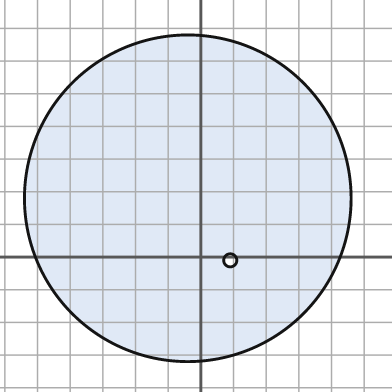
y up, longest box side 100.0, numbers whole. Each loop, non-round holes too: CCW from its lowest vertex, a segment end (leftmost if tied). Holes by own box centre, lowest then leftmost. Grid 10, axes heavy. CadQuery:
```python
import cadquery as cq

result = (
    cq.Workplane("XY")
    .moveTo(-4.0, 18.0)
    .circle(50.0)
    .moveTo(9.0, -1.0)
    .circle(2.0)
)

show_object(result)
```